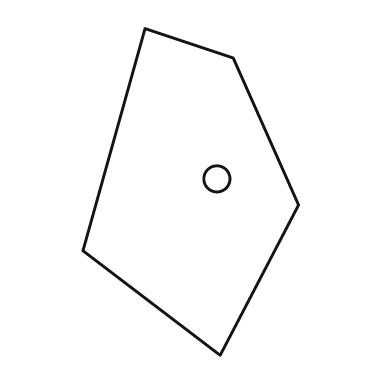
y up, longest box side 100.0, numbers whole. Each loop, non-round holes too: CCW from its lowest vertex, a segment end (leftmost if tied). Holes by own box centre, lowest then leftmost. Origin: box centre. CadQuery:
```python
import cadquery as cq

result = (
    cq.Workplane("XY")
    .moveTo(9.0, -50.0)
    .lineTo(33.0, -4.0)
    .lineTo(13.0, 41.0)
    .lineTo(-14.0, 50.0)
    .lineTo(-33.0, -18.0)
    .close()
    .moveTo(8.0, 4.0)
    .circle(4.0)
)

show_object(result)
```